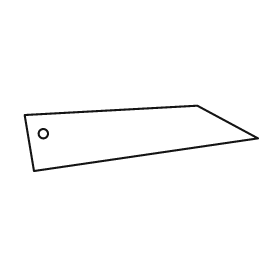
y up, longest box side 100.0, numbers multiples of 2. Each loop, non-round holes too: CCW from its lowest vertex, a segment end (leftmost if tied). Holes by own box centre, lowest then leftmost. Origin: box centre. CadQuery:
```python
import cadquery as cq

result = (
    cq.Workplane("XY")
    .moveTo(-46.0, -14.0)
    .lineTo(50.0, 0.0)
    .lineTo(24.0, 14.0)
    .lineTo(-50.0, 10.0)
    .close()
    .moveTo(-42.0, 2.0)
    .circle(2.0)
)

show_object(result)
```